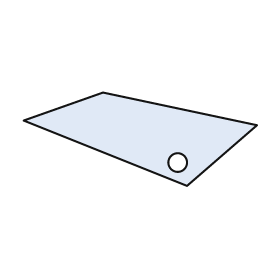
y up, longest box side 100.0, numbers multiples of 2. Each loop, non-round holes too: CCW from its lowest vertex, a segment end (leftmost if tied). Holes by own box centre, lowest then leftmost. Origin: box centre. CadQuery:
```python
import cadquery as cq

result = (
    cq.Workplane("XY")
    .moveTo(20.0, -20.0)
    .lineTo(50.0, 6.0)
    .lineTo(-16.0, 20.0)
    .lineTo(-50.0, 8.0)
    .close()
    .moveTo(16.0, -10.0)
    .circle(4.0)
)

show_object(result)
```